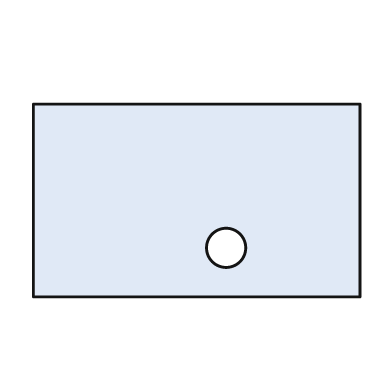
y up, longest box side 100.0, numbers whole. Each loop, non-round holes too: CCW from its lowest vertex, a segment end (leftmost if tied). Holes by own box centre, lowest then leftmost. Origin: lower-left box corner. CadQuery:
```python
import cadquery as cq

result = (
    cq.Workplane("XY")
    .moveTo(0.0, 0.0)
    .lineTo(100.0, 0.0)
    .lineTo(100.0, 59.0)
    .lineTo(0.0, 59.0)
    .close()
    .moveTo(59.0, 15.0)
    .circle(6.0)
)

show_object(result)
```